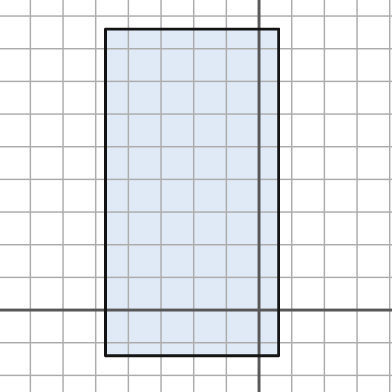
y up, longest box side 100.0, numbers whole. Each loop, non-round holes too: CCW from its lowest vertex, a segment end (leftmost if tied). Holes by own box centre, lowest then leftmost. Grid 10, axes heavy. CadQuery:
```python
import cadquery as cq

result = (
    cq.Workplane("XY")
    .moveTo(-47.0, -14.0)
    .lineTo(6.0, -14.0)
    .lineTo(6.0, 86.0)
    .lineTo(-47.0, 86.0)
    .close()
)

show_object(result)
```